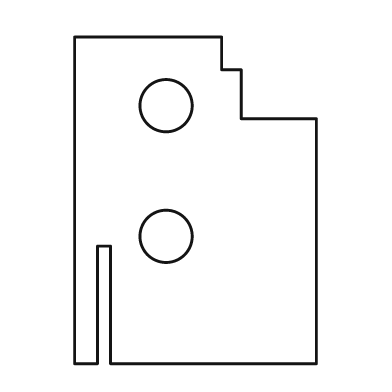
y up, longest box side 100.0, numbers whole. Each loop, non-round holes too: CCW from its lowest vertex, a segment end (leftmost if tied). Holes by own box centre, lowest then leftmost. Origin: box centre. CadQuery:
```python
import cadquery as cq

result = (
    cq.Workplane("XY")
    .moveTo(-37.0, -50.0)
    .lineTo(-30.0, -50.0)
    .lineTo(-30.0, -14.0)
    .lineTo(-26.0, -14.0)
    .lineTo(-26.0, -50.0)
    .lineTo(37.0, -50.0)
    .lineTo(37.0, 25.0)
    .lineTo(14.0, 25.0)
    .lineTo(14.0, 40.0)
    .lineTo(8.0, 40.0)
    .lineTo(8.0, 50.0)
    .lineTo(-37.0, 50.0)
    .close()
    .moveTo(-9.0, -11.0)
    .circle(8.0)
    .moveTo(-9.0, 29.0)
    .circle(8.0)
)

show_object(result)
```